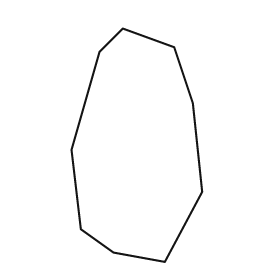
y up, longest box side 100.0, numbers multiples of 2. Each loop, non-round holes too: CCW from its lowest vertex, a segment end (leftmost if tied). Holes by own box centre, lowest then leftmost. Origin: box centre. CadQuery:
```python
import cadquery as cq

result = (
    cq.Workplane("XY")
    .moveTo(12.0, -50.0)
    .lineTo(28.0, -20.0)
    .lineTo(24.0, 18.0)
    .lineTo(16.0, 42.0)
    .lineTo(-6.0, 50.0)
    .lineTo(-16.0, 40.0)
    .lineTo(-28.0, -2.0)
    .lineTo(-24.0, -36.0)
    .lineTo(-10.0, -46.0)
    .close()
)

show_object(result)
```